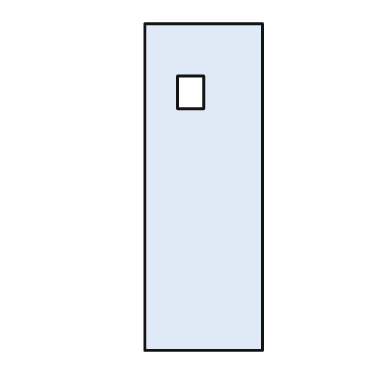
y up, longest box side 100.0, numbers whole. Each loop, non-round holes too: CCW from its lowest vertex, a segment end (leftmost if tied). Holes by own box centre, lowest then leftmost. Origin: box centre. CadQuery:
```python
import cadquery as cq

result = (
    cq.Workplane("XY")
    .moveTo(-18.0, -50.0)
    .lineTo(18.0, -50.0)
    .lineTo(18.0, 50.0)
    .lineTo(-18.0, 50.0)
    .close()
    .moveTo(-8.0, 24.0)
    .lineTo(0.0, 24.0)
    .lineTo(0.0, 34.0)
    .lineTo(-8.0, 34.0)
    .close()
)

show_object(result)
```